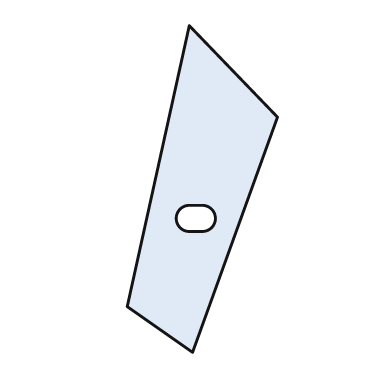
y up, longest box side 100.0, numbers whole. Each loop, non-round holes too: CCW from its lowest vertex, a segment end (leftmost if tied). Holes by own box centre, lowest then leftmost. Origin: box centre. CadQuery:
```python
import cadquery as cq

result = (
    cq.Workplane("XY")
    .moveTo(-3.0, -50.0)
    .lineTo(23.0, 22.0)
    .lineTo(-4.0, 50.0)
    .lineTo(-23.0, -36.0)
    .close()
    .moveTo(-4.0, -13.0)
    .lineTo(0.0, -13.0)
    .threePointArc((4.0, -9.0), (0.0, -5.0))
    .lineTo(-4.0, -5.0)
    .threePointArc((-8.0, -9.0), (-4.0, -13.0))
    .close()
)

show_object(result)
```